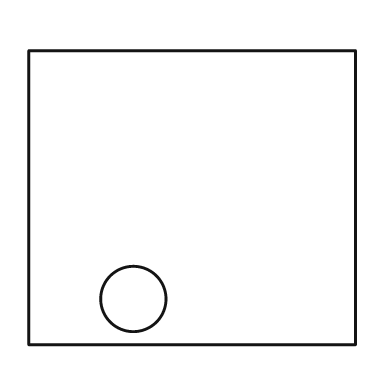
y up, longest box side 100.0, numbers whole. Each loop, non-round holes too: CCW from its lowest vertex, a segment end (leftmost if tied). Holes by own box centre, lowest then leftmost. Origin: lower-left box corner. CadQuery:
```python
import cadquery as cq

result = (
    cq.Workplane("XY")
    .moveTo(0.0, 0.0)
    .lineTo(100.0, 0.0)
    .lineTo(100.0, 90.0)
    .lineTo(0.0, 90.0)
    .close()
    .moveTo(32.0, 14.0)
    .circle(10.0)
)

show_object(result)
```